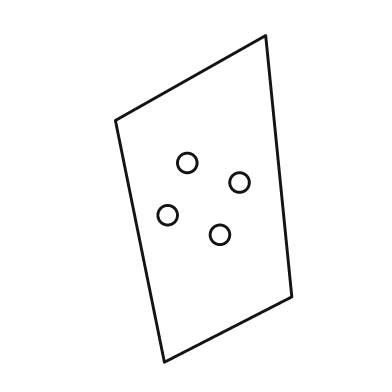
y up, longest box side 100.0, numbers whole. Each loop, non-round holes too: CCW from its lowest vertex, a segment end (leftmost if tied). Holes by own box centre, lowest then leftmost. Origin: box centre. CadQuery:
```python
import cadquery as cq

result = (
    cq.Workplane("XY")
    .moveTo(-12.0, -50.0)
    .lineTo(27.0, -30.0)
    .lineTo(19.0, 50.0)
    .lineTo(-27.0, 24.0)
    .close()
    .moveTo(5.0, -11.0)
    .circle(3.0)
    .moveTo(-11.0, -5.0)
    .circle(3.0)
    .moveTo(11.0, 5.0)
    .circle(3.0)
    .moveTo(-5.0, 11.0)
    .circle(3.0)
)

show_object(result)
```